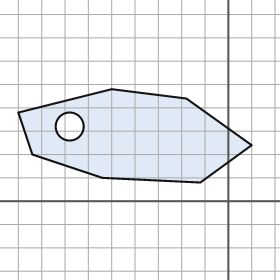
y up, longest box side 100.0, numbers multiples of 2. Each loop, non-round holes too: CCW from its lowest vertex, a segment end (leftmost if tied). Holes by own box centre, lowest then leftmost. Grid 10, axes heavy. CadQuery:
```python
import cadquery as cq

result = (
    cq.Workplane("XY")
    .moveTo(-12.0, 8.0)
    .lineTo(10.0, 24.0)
    .lineTo(-18.0, 44.0)
    .lineTo(-50.0, 48.0)
    .lineTo(-90.0, 38.0)
    .lineTo(-84.0, 20.0)
    .lineTo(-54.0, 10.0)
    .close()
    .moveTo(-68.0, 32.0)
    .circle(6.0)
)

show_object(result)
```